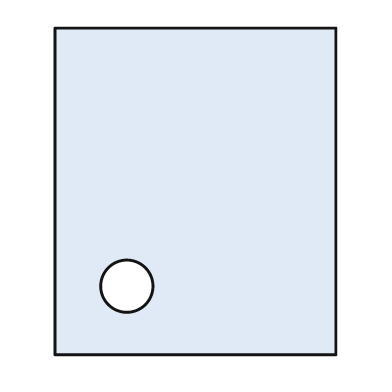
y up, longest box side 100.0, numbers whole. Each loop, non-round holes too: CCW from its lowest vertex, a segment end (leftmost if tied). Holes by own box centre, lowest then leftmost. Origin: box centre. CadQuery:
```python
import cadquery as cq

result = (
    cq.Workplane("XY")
    .moveTo(-43.0, -50.0)
    .lineTo(43.0, -50.0)
    .lineTo(43.0, 50.0)
    .lineTo(-43.0, 50.0)
    .close()
    .moveTo(-21.0, -29.0)
    .circle(8.0)
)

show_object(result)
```